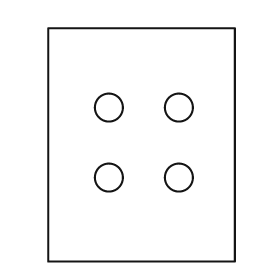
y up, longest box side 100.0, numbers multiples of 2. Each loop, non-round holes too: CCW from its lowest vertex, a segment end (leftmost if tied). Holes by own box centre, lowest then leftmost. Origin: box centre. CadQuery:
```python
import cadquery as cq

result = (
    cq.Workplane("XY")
    .moveTo(-40.0, -50.0)
    .lineTo(40.0, -50.0)
    .lineTo(40.0, 50.0)
    .lineTo(-40.0, 50.0)
    .close()
    .moveTo(-14.0, -14.0)
    .circle(6.0)
    .moveTo(16.0, -14.0)
    .circle(6.0)
    .moveTo(-14.0, 16.0)
    .circle(6.0)
    .moveTo(16.0, 16.0)
    .circle(6.0)
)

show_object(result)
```